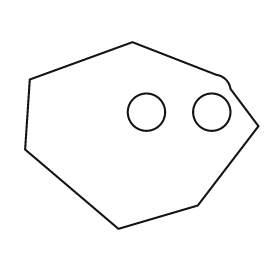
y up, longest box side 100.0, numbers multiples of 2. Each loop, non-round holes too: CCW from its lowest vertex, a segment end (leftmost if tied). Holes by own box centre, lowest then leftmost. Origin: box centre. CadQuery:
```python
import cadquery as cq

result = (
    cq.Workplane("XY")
    .moveTo(-10.0, -40.0)
    .lineTo(24.0, -30.0)
    .lineTo(50.0, 4.0)
    .lineTo(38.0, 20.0)
    .threePointArc((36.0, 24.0), (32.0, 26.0))
    .lineTo(-4.0, 40.0)
    .lineTo(-48.0, 24.0)
    .lineTo(-50.0, -6.0)
    .close()
    .moveTo(2.0, 10.0)
    .circle(8.0)
    .moveTo(30.0, 10.0)
    .circle(8.0)
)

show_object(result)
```